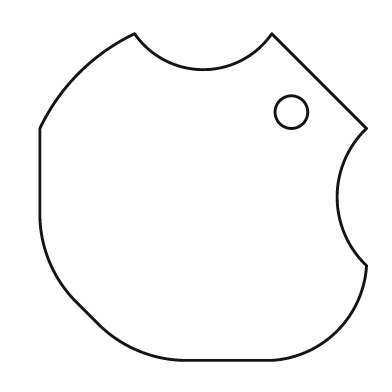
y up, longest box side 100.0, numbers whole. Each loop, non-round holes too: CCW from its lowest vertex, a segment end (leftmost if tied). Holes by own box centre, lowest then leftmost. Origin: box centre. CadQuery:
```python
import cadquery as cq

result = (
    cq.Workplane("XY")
    .moveTo(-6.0, -50.0)
    .lineTo(21.0, -50.0)
    .threePointArc((41.0, -41.0), (50.0, -21.0))
    .threePointArc((41.0, 0.0), (50.0, 21.0))
    .lineTo(21.0, 50.0)
    .threePointArc((0.0, 39.0), (-21.0, 50.0))
    .threePointArc((-38.0, 38.0), (-50.0, 21.0))
    .lineTo(-50.0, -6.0)
    .threePointArc((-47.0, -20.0), (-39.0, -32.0))
    .lineTo(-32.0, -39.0)
    .threePointArc((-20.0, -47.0), (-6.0, -50.0))
    .close()
    .moveTo(27.0, 26.0)
    .circle(5.0)
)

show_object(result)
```